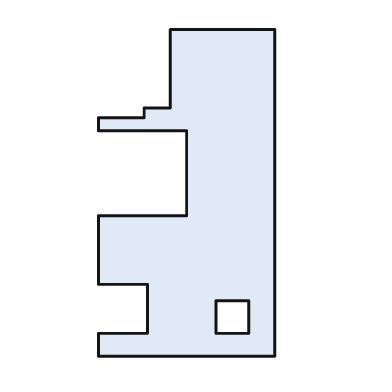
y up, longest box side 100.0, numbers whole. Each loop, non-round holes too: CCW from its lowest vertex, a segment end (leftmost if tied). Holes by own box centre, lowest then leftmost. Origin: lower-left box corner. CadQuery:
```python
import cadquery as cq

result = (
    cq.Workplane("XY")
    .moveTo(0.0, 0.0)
    .lineTo(54.0, 0.0)
    .lineTo(54.0, 100.0)
    .lineTo(22.0, 100.0)
    .lineTo(22.0, 76.0)
    .lineTo(14.0, 76.0)
    .lineTo(14.0, 73.0)
    .lineTo(0.0, 73.0)
    .lineTo(0.0, 69.0)
    .lineTo(27.0, 69.0)
    .lineTo(27.0, 43.0)
    .lineTo(0.0, 43.0)
    .lineTo(0.0, 22.0)
    .lineTo(15.0, 22.0)
    .lineTo(15.0, 7.0)
    .lineTo(0.0, 7.0)
    .close()
    .moveTo(36.0, 7.0)
    .lineTo(46.0, 7.0)
    .lineTo(46.0, 17.0)
    .lineTo(36.0, 17.0)
    .close()
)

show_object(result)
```